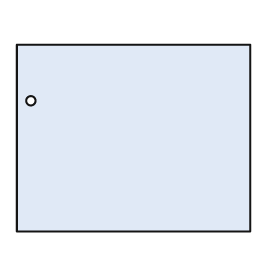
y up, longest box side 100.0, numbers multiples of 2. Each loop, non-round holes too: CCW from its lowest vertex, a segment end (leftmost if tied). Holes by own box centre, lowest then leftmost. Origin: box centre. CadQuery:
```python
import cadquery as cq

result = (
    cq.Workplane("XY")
    .moveTo(-50.0, -40.0)
    .lineTo(50.0, -40.0)
    .lineTo(50.0, 40.0)
    .lineTo(-50.0, 40.0)
    .close()
    .moveTo(-44.0, 16.0)
    .circle(2.0)
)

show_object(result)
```